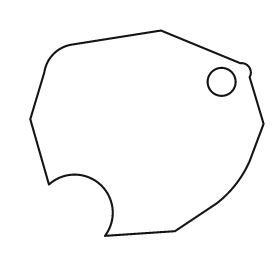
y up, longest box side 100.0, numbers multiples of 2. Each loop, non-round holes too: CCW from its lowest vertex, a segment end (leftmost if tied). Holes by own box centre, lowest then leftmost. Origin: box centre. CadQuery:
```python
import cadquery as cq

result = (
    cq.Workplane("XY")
    .moveTo(-18.0, -44.0)
    .lineTo(12.0, -42.0)
    .lineTo(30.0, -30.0)
    .threePointArc((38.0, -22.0), (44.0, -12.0))
    .lineTo(50.0, 4.0)
    .lineTo(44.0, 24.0)
    .threePointArc((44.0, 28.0), (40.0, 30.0))
    .lineTo(6.0, 44.0)
    .lineTo(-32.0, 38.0)
    .threePointArc((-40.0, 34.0), (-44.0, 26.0))
    .lineTo(-50.0, 6.0)
    .lineTo(-42.0, -22.0)
    .threePointArc((-20.0, -22.0), (-18.0, -44.0))
    .close()
    .moveTo(32.0, 22.0)
    .circle(6.0)
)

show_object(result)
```